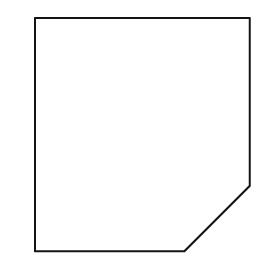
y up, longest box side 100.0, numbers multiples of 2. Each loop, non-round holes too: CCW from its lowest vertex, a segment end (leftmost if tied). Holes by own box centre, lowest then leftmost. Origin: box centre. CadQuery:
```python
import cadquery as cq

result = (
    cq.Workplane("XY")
    .moveTo(-46.0, -50.0)
    .lineTo(18.0, -50.0)
    .lineTo(46.0, -22.0)
    .lineTo(46.0, 50.0)
    .lineTo(-46.0, 50.0)
    .close()
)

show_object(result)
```